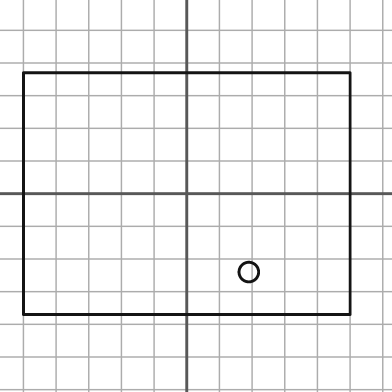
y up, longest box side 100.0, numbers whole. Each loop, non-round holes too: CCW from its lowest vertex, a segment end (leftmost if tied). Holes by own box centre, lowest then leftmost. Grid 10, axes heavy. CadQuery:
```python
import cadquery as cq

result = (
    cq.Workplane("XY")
    .moveTo(-50.0, -37.0)
    .lineTo(50.0, -37.0)
    .lineTo(50.0, 37.0)
    .lineTo(-50.0, 37.0)
    .close()
    .moveTo(19.0, -24.0)
    .circle(3.0)
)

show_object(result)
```